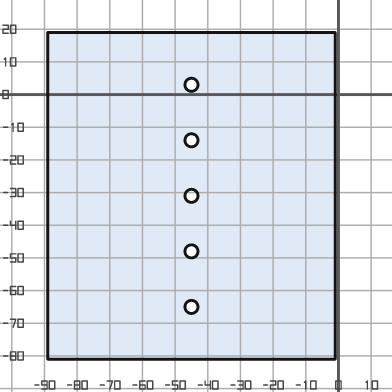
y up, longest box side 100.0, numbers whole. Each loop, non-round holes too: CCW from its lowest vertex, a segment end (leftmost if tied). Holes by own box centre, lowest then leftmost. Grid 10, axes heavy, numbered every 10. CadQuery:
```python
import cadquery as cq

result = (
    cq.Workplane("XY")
    .moveTo(-89.0, -81.0)
    .lineTo(-1.0, -81.0)
    .lineTo(-1.0, 19.0)
    .lineTo(-89.0, 19.0)
    .close()
    .moveTo(-45.0, -65.0)
    .circle(2.0)
    .moveTo(-45.0, -48.0)
    .circle(2.0)
    .moveTo(-45.0, -31.0)
    .circle(2.0)
    .moveTo(-45.0, -14.0)
    .circle(2.0)
    .moveTo(-45.0, 3.0)
    .circle(2.0)
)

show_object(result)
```